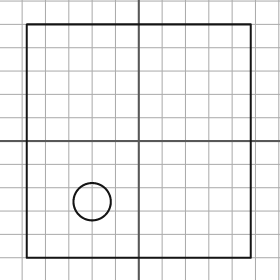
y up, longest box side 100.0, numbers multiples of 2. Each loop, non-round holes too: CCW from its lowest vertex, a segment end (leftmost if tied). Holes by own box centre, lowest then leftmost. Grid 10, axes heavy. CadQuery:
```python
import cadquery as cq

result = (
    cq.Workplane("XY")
    .moveTo(-48.0, -50.0)
    .lineTo(48.0, -50.0)
    .lineTo(48.0, 50.0)
    .lineTo(-48.0, 50.0)
    .close()
    .moveTo(-20.0, -26.0)
    .circle(8.0)
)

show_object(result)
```